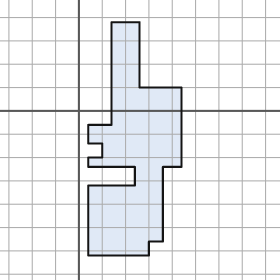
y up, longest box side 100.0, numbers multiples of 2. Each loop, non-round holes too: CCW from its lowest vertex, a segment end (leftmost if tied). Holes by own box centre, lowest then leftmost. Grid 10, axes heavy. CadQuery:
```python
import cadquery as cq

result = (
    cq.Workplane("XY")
    .moveTo(4.0, -62.0)
    .lineTo(30.0, -62.0)
    .lineTo(30.0, -56.0)
    .lineTo(36.0, -56.0)
    .lineTo(36.0, -24.0)
    .lineTo(44.0, -24.0)
    .lineTo(44.0, 10.0)
    .lineTo(26.0, 10.0)
    .lineTo(26.0, 38.0)
    .lineTo(14.0, 38.0)
    .lineTo(14.0, -6.0)
    .lineTo(4.0, -6.0)
    .lineTo(4.0, -14.0)
    .lineTo(10.0, -14.0)
    .lineTo(10.0, -20.0)
    .lineTo(4.0, -20.0)
    .lineTo(4.0, -24.0)
    .lineTo(24.0, -24.0)
    .lineTo(24.0, -32.0)
    .lineTo(4.0, -32.0)
    .close()
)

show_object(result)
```